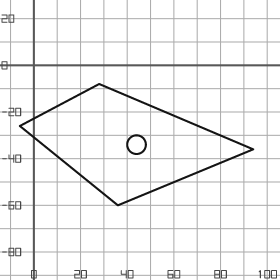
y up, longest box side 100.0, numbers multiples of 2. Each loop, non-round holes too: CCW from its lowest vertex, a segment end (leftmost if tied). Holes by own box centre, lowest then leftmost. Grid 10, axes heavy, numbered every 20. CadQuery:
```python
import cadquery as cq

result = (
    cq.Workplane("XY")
    .moveTo(36.0, -60.0)
    .lineTo(94.0, -36.0)
    .lineTo(28.0, -8.0)
    .lineTo(-6.0, -26.0)
    .close()
    .moveTo(44.0, -34.0)
    .circle(4.0)
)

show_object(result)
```